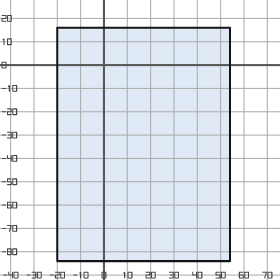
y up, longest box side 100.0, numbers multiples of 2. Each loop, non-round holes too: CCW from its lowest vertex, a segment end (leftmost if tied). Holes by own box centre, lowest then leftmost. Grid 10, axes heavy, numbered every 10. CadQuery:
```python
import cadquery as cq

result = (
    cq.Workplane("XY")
    .moveTo(-20.0, -84.0)
    .lineTo(54.0, -84.0)
    .lineTo(54.0, 16.0)
    .lineTo(-20.0, 16.0)
    .close()
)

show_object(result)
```